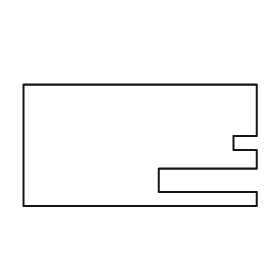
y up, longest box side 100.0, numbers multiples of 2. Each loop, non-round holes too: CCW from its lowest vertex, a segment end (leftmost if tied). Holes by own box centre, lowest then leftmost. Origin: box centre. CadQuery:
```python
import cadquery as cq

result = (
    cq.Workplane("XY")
    .moveTo(-50.0, -26.0)
    .lineTo(50.0, -26.0)
    .lineTo(50.0, -20.0)
    .lineTo(8.0, -20.0)
    .lineTo(8.0, -10.0)
    .lineTo(50.0, -10.0)
    .lineTo(50.0, -2.0)
    .lineTo(40.0, -2.0)
    .lineTo(40.0, 4.0)
    .lineTo(50.0, 4.0)
    .lineTo(50.0, 26.0)
    .lineTo(-50.0, 26.0)
    .close()
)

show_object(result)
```